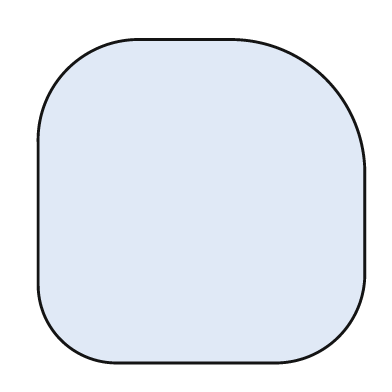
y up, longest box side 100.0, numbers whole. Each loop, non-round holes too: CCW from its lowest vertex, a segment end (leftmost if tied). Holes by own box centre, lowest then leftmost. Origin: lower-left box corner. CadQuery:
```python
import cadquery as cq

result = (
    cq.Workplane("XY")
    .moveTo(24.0, 0.0)
    .lineTo(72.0, 0.0)
    .threePointArc((92.0, 8.0), (100.0, 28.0))
    .lineTo(100.0, 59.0)
    .threePointArc((88.0, 87.0), (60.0, 99.0))
    .lineTo(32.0, 99.0)
    .threePointArc((9.0, 90.0), (0.0, 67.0))
    .lineTo(0.0, 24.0)
    .threePointArc((7.0, 7.0), (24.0, 0.0))
    .close()
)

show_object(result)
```